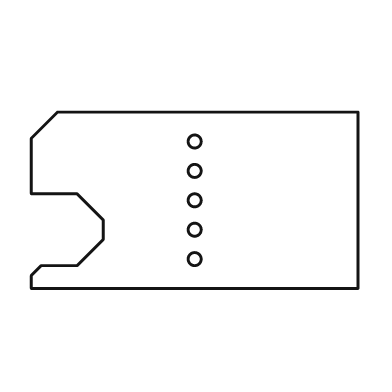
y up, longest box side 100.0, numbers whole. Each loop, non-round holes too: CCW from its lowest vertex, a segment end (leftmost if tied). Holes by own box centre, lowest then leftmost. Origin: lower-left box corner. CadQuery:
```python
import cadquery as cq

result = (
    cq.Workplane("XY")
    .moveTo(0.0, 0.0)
    .lineTo(100.0, 0.0)
    .lineTo(100.0, 54.0)
    .lineTo(8.0, 54.0)
    .lineTo(0.0, 46.0)
    .lineTo(0.0, 29.0)
    .lineTo(14.0, 29.0)
    .lineTo(22.0, 21.0)
    .lineTo(22.0, 15.0)
    .lineTo(14.0, 7.0)
    .lineTo(3.0, 7.0)
    .lineTo(0.0, 4.0)
    .close()
    .moveTo(50.0, 9.0)
    .circle(2.0)
    .moveTo(50.0, 18.0)
    .circle(2.0)
    .moveTo(50.0, 27.0)
    .circle(2.0)
    .moveTo(50.0, 36.0)
    .circle(2.0)
    .moveTo(50.0, 45.0)
    .circle(2.0)
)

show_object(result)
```